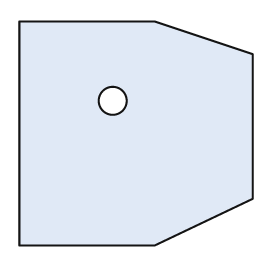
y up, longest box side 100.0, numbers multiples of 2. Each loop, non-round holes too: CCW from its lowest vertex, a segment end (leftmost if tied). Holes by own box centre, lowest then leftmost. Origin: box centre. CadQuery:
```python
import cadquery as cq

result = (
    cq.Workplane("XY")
    .moveTo(-50.0, -48.0)
    .lineTo(8.0, -48.0)
    .lineTo(50.0, -28.0)
    .lineTo(50.0, 34.0)
    .lineTo(8.0, 48.0)
    .lineTo(-50.0, 48.0)
    .close()
    .moveTo(-10.0, 14.0)
    .circle(6.0)
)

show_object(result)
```